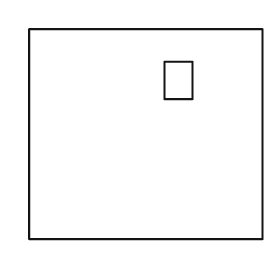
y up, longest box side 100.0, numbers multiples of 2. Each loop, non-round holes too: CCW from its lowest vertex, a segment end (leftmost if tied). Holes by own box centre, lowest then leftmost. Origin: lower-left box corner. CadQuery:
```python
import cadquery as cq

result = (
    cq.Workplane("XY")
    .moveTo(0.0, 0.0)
    .lineTo(100.0, 0.0)
    .lineTo(100.0, 90.0)
    .lineTo(0.0, 90.0)
    .close()
    .moveTo(58.0, 60.0)
    .lineTo(70.0, 60.0)
    .lineTo(70.0, 76.0)
    .lineTo(58.0, 76.0)
    .close()
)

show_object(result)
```